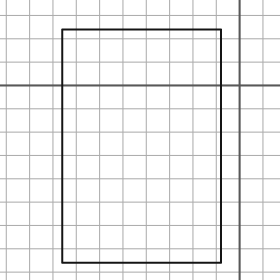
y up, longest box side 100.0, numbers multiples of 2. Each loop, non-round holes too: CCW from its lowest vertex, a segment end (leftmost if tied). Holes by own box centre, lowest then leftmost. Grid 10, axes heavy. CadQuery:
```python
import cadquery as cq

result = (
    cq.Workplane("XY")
    .moveTo(-76.0, -76.0)
    .lineTo(-8.0, -76.0)
    .lineTo(-8.0, 24.0)
    .lineTo(-76.0, 24.0)
    .close()
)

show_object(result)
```